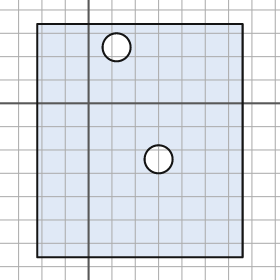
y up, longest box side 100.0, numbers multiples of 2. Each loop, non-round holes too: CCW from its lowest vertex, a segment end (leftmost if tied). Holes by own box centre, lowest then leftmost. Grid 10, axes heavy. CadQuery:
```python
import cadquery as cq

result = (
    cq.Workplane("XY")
    .moveTo(-22.0, -66.0)
    .lineTo(66.0, -66.0)
    .lineTo(66.0, 34.0)
    .lineTo(-22.0, 34.0)
    .close()
    .moveTo(30.0, -24.0)
    .circle(6.0)
    .moveTo(12.0, 24.0)
    .circle(6.0)
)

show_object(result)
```